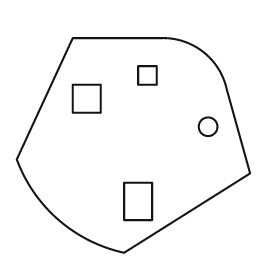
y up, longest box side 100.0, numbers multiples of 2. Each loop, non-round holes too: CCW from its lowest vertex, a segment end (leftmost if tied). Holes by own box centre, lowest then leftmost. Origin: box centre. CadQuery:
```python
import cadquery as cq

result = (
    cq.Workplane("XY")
    .moveTo(-4.0, -46.0)
    .lineTo(50.0, -12.0)
    .lineTo(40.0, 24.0)
    .threePointArc((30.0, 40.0), (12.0, 46.0))
    .lineTo(-26.0, 46.0)
    .lineTo(-50.0, -6.0)
    .threePointArc((-32.0, -32.0), (-4.0, -46.0))
    .close()
    .moveTo(-4.0, -32.0)
    .lineTo(8.0, -32.0)
    .lineTo(8.0, -16.0)
    .lineTo(-4.0, -16.0)
    .close()
    .moveTo(32.0, 8.0)
    .circle(4.0)
    .moveTo(-26.0, 14.0)
    .lineTo(-14.0, 14.0)
    .lineTo(-14.0, 26.0)
    .lineTo(-26.0, 26.0)
    .close()
    .moveTo(2.0, 26.0)
    .lineTo(10.0, 26.0)
    .lineTo(10.0, 34.0)
    .lineTo(2.0, 34.0)
    .close()
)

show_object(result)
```